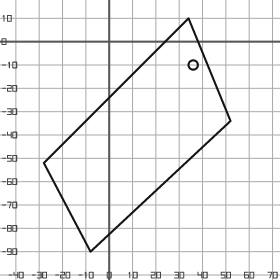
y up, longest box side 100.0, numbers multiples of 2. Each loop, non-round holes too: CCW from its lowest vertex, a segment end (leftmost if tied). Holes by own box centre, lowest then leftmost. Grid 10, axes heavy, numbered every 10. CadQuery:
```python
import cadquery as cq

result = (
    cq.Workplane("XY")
    .moveTo(-8.0, -90.0)
    .lineTo(52.0, -34.0)
    .lineTo(34.0, 10.0)
    .lineTo(-28.0, -52.0)
    .close()
    .moveTo(36.0, -10.0)
    .circle(2.0)
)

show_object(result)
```